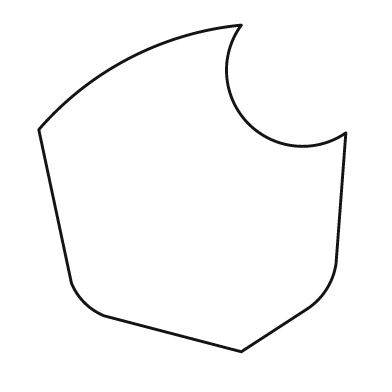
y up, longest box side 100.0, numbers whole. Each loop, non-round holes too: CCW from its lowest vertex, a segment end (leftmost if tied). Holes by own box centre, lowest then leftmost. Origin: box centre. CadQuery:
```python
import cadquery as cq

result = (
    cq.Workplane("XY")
    .moveTo(15.0, -50.0)
    .lineTo(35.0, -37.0)
    .threePointArc((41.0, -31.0), (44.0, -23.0))
    .lineTo(47.0, 17.0)
    .threePointArc((17.0, 20.0), (15.0, 50.0))
    .threePointArc((-19.0, 40.0), (-47.0, 18.0))
    .lineTo(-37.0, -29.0)
    .threePointArc((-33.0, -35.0), (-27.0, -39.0))
    .close()
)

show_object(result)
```